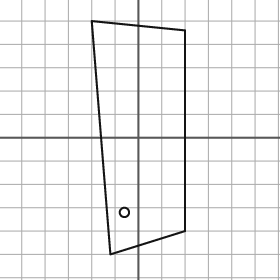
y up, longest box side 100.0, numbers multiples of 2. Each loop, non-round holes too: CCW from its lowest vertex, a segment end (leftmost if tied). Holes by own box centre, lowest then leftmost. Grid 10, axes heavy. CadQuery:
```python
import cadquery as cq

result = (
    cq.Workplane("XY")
    .moveTo(-12.0, -50.0)
    .lineTo(20.0, -40.0)
    .lineTo(20.0, 46.0)
    .lineTo(-20.0, 50.0)
    .close()
    .moveTo(-6.0, -32.0)
    .circle(2.0)
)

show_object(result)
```